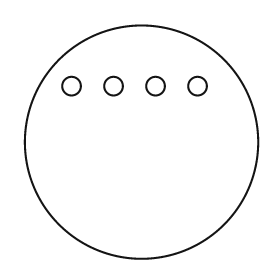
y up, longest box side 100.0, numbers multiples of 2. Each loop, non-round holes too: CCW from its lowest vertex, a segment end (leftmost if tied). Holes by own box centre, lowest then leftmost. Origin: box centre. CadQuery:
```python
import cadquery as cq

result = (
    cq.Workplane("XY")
    .moveTo(0.0, 0.0)
    .circle(50.0)
    .moveTo(-30.0, 24.0)
    .circle(4.0)
    .moveTo(-12.0, 24.0)
    .circle(4.0)
    .moveTo(6.0, 24.0)
    .circle(4.0)
    .moveTo(24.0, 24.0)
    .circle(4.0)
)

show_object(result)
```